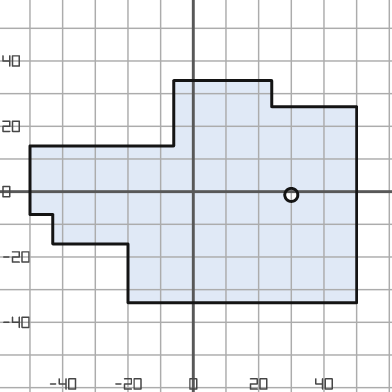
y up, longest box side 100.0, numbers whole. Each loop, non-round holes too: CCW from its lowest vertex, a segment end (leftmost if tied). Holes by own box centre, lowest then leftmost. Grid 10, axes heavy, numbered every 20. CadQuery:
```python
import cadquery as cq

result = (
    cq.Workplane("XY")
    .moveTo(-20.0, -34.0)
    .lineTo(50.0, -34.0)
    .lineTo(50.0, 26.0)
    .lineTo(24.0, 26.0)
    .lineTo(24.0, 34.0)
    .lineTo(-6.0, 34.0)
    .lineTo(-6.0, 14.0)
    .lineTo(-50.0, 14.0)
    .lineTo(-50.0, -7.0)
    .lineTo(-43.0, -7.0)
    .lineTo(-43.0, -16.0)
    .lineTo(-20.0, -16.0)
    .close()
    .moveTo(30.0, -1.0)
    .circle(2.0)
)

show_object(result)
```